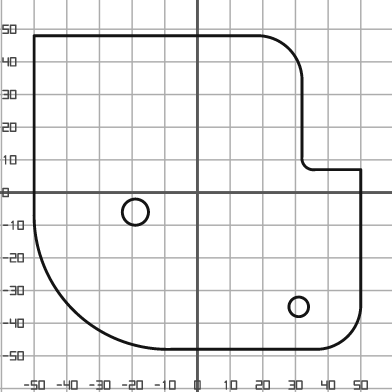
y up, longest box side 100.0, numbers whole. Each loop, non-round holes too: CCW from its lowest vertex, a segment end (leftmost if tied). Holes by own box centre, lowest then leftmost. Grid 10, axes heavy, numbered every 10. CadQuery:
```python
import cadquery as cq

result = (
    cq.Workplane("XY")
    .moveTo(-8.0, -48.0)
    .lineTo(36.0, -48.0)
    .threePointArc((46.0, -44.0), (50.0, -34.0))
    .lineTo(50.0, 7.0)
    .lineTo(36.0, 7.0)
    .threePointArc((33.0, 8.0), (32.0, 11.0))
    .lineTo(32.0, 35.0)
    .threePointArc((28.0, 44.0), (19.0, 48.0))
    .lineTo(-50.0, 48.0)
    .lineTo(-50.0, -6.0)
    .threePointArc((-38.0, -36.0), (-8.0, -48.0))
    .close()
    .moveTo(31.0, -35.0)
    .circle(3.0)
    .moveTo(-19.0, -6.0)
    .circle(4.0)
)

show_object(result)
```